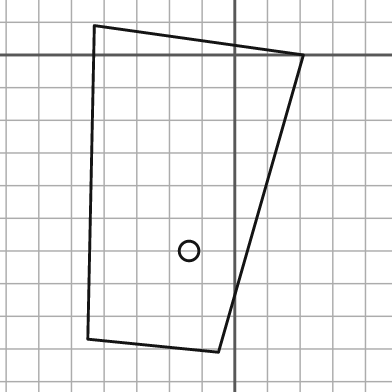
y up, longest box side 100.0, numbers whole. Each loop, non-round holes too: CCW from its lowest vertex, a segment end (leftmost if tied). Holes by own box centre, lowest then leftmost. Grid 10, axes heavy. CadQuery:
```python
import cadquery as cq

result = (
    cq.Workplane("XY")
    .moveTo(-5.0, -91.0)
    .lineTo(21.0, 0.0)
    .lineTo(-43.0, 9.0)
    .lineTo(-45.0, -87.0)
    .close()
    .moveTo(-14.0, -60.0)
    .circle(3.0)
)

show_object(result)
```